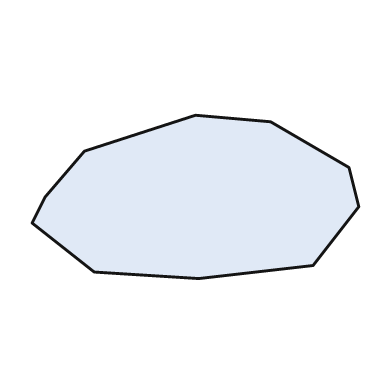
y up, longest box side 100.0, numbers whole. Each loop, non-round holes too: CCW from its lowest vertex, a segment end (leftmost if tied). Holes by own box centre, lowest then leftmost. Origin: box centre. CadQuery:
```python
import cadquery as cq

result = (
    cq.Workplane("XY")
    .moveTo(1.0, -25.0)
    .lineTo(36.0, -21.0)
    .lineTo(50.0, -3.0)
    .lineTo(47.0, 9.0)
    .lineTo(23.0, 23.0)
    .lineTo(0.0, 25.0)
    .lineTo(-34.0, 14.0)
    .lineTo(-46.0, 0.0)
    .lineTo(-50.0, -8.0)
    .lineTo(-31.0, -23.0)
    .close()
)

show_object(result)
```